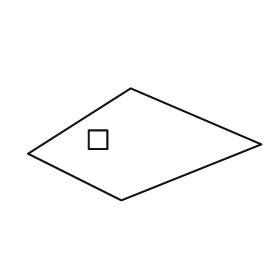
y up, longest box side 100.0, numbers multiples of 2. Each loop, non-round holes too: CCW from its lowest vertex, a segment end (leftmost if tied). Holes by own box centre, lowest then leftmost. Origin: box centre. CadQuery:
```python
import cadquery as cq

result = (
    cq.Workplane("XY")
    .moveTo(-10.0, -24.0)
    .lineTo(50.0, 0.0)
    .lineTo(-6.0, 24.0)
    .lineTo(-50.0, -4.0)
    .close()
    .moveTo(-24.0, -2.0)
    .lineTo(-16.0, -2.0)
    .lineTo(-16.0, 6.0)
    .lineTo(-24.0, 6.0)
    .close()
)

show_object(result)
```